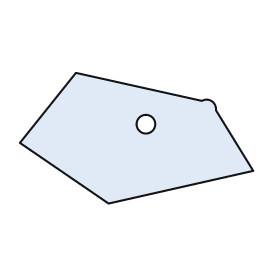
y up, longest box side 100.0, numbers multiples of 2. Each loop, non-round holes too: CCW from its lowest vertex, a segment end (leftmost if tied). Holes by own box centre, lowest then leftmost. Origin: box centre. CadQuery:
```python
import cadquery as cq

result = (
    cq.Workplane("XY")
    .moveTo(-12.0, -28.0)
    .lineTo(50.0, -14.0)
    .lineTo(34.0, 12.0)
    .threePointArc((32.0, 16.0), (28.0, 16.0))
    .lineTo(-26.0, 28.0)
    .lineTo(-50.0, -2.0)
    .close()
    .moveTo(4.0, 6.0)
    .circle(4.0)
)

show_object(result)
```